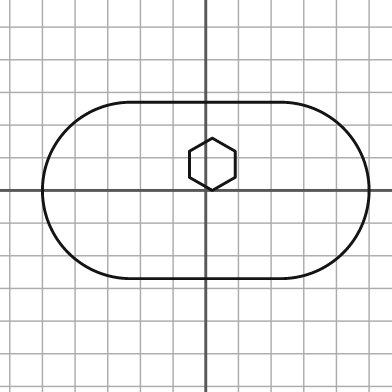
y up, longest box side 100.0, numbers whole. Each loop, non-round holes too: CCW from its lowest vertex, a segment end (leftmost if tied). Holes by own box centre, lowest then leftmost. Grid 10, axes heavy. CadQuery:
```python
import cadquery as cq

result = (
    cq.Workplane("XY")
    .moveTo(-23.0, -27.0)
    .lineTo(23.0, -27.0)
    .threePointArc((50.0, 0.0), (23.0, 27.0))
    .lineTo(-23.0, 27.0)
    .threePointArc((-50.0, 0.0), (-23.0, -27.0))
    .close()
    .moveTo(2.0, 0.0)
    .lineTo(9.0, 4.0)
    .lineTo(9.0, 12.0)
    .lineTo(2.0, 16.0)
    .lineTo(-5.0, 12.0)
    .lineTo(-5.0, 4.0)
    .close()
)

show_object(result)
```